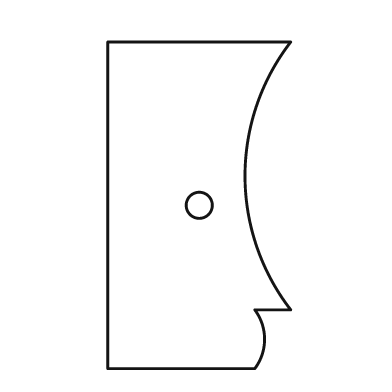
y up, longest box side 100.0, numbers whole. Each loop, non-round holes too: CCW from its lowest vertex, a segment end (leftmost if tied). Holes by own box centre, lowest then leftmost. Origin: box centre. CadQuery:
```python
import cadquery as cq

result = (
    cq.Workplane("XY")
    .moveTo(-28.0, -50.0)
    .lineTo(17.0, -50.0)
    .threePointArc((20.0, -41.0), (17.0, -32.0))
    .lineTo(28.0, -32.0)
    .threePointArc((14.0, 9.0), (28.0, 50.0))
    .lineTo(-28.0, 50.0)
    .close()
    .moveTo(0.0, 0.0)
    .circle(4.0)
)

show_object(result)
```